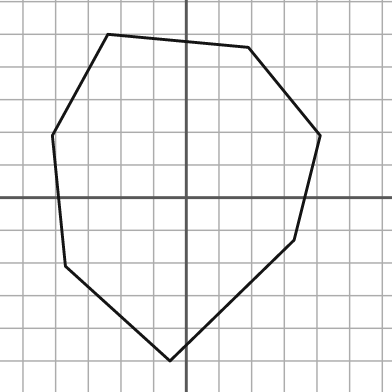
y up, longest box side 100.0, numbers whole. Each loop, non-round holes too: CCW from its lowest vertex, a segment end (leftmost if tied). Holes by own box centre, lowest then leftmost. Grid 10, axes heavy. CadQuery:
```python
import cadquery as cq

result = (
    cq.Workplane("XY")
    .moveTo(-5.0, -50.0)
    .lineTo(33.0, -13.0)
    .lineTo(41.0, 19.0)
    .lineTo(19.0, 46.0)
    .lineTo(-24.0, 50.0)
    .lineTo(-41.0, 19.0)
    .lineTo(-37.0, -21.0)
    .close()
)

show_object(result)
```